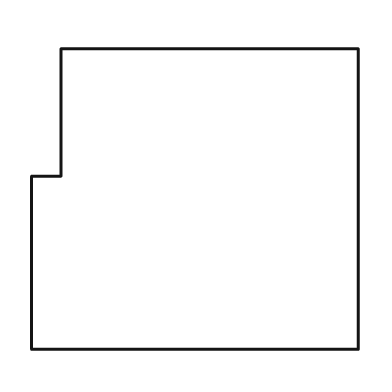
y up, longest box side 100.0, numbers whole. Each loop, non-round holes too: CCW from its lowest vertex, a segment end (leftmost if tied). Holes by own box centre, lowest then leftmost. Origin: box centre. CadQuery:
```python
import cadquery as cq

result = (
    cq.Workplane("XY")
    .moveTo(-50.0, -46.0)
    .lineTo(50.0, -46.0)
    .lineTo(50.0, 46.0)
    .lineTo(-41.0, 46.0)
    .lineTo(-41.0, 7.0)
    .lineTo(-50.0, 7.0)
    .close()
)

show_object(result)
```